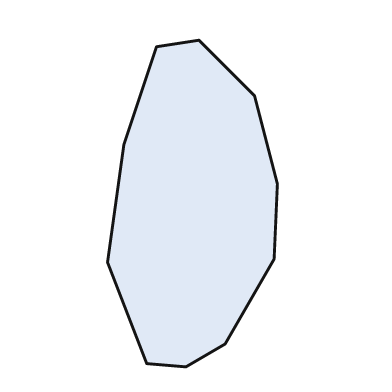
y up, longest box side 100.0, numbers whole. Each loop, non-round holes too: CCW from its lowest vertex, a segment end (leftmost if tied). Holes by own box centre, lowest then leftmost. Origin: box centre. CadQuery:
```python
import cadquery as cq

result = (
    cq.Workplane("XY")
    .moveTo(-2.0, -50.0)
    .lineTo(10.0, -43.0)
    .lineTo(25.0, -17.0)
    .lineTo(26.0, 6.0)
    .lineTo(19.0, 33.0)
    .lineTo(2.0, 50.0)
    .lineTo(-11.0, 48.0)
    .lineTo(-21.0, 18.0)
    .lineTo(-26.0, -18.0)
    .lineTo(-14.0, -49.0)
    .close()
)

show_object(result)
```